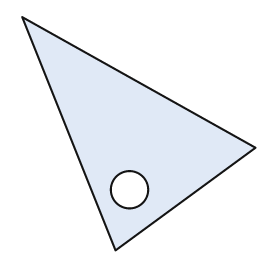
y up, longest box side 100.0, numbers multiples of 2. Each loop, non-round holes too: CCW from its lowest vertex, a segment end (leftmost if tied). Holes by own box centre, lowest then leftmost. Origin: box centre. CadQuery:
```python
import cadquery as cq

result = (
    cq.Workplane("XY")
    .moveTo(-10.0, -50.0)
    .lineTo(50.0, -6.0)
    .lineTo(-50.0, 50.0)
    .close()
    .moveTo(-4.0, -24.0)
    .circle(8.0)
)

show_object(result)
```